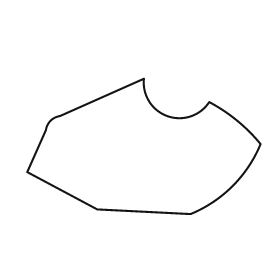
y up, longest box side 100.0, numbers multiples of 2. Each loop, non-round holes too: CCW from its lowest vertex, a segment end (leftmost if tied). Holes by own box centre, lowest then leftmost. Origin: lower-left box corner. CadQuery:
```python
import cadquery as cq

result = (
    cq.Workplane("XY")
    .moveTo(70.0, 0.0)
    .threePointArc((88.0, 12.0), (100.0, 30.0))
    .threePointArc((90.0, 40.0), (78.0, 48.0))
    .threePointArc((60.0, 42.0), (50.0, 58.0))
    .lineTo(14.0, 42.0)
    .threePointArc((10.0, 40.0), (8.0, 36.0))
    .lineTo(0.0, 18.0)
    .lineTo(30.0, 2.0)
    .close()
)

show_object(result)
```